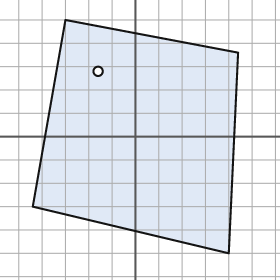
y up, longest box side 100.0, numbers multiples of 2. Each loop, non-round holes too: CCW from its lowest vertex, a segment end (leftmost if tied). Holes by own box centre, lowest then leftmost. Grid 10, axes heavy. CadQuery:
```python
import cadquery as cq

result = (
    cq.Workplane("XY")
    .moveTo(40.0, -50.0)
    .lineTo(44.0, 36.0)
    .lineTo(-30.0, 50.0)
    .lineTo(-44.0, -30.0)
    .close()
    .moveTo(-16.0, 28.0)
    .circle(2.0)
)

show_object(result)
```